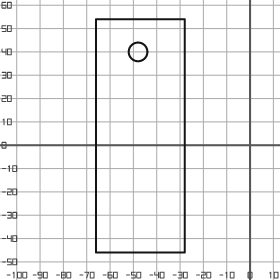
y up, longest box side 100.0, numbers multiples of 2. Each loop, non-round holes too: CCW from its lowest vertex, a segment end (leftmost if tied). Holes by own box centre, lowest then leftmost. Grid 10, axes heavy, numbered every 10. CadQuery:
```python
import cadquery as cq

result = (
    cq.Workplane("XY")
    .moveTo(-66.0, -46.0)
    .lineTo(-28.0, -46.0)
    .lineTo(-28.0, 54.0)
    .lineTo(-66.0, 54.0)
    .close()
    .moveTo(-48.0, 40.0)
    .circle(4.0)
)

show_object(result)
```